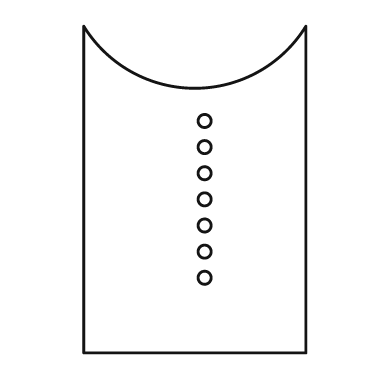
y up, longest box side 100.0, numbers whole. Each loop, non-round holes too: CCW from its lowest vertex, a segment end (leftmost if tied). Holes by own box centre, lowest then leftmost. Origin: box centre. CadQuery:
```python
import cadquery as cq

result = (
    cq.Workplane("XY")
    .moveTo(-34.0, -50.0)
    .lineTo(34.0, -50.0)
    .lineTo(34.0, 50.0)
    .threePointArc((0.0, 31.0), (-34.0, 50.0))
    .close()
    .moveTo(3.0, -27.0)
    .circle(2.0)
    .moveTo(3.0, -19.0)
    .circle(2.0)
    .moveTo(3.0, -11.0)
    .circle(2.0)
    .moveTo(3.0, -3.0)
    .circle(2.0)
    .moveTo(3.0, 5.0)
    .circle(2.0)
    .moveTo(3.0, 13.0)
    .circle(2.0)
    .moveTo(3.0, 21.0)
    .circle(2.0)
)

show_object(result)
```